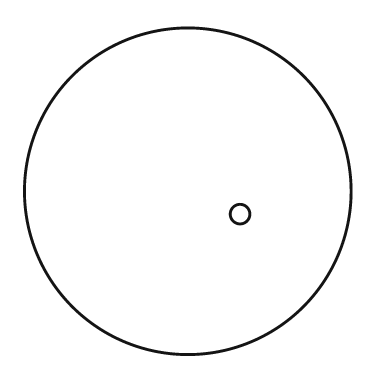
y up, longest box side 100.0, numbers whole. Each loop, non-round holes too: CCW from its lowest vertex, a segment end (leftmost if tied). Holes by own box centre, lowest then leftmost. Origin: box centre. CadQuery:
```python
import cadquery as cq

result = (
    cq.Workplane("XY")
    .moveTo(0.0, 0.0)
    .circle(50.0)
    .moveTo(16.0, -7.0)
    .circle(3.0)
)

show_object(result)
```